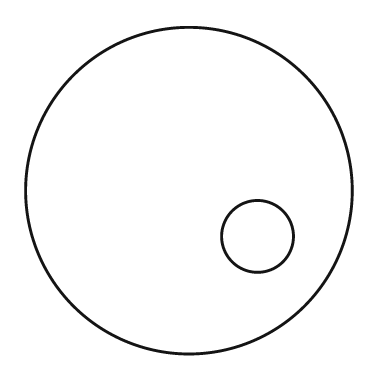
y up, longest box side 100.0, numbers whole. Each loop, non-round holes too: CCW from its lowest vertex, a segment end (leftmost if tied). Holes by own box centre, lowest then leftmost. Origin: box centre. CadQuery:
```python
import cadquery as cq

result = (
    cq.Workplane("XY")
    .moveTo(0.0, 0.0)
    .circle(50.0)
    .moveTo(21.0, -14.0)
    .circle(11.0)
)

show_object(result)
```